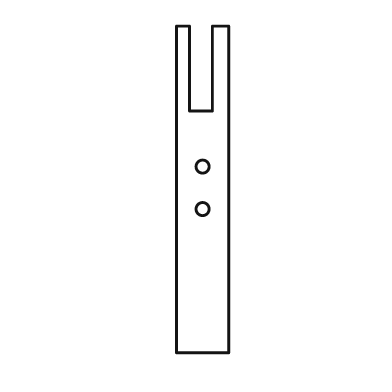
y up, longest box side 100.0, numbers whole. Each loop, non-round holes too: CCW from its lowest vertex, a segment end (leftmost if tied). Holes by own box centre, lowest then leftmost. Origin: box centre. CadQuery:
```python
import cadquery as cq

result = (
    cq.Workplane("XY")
    .moveTo(-8.0, -50.0)
    .lineTo(8.0, -50.0)
    .lineTo(8.0, 50.0)
    .lineTo(3.0, 50.0)
    .lineTo(3.0, 24.0)
    .lineTo(-4.0, 24.0)
    .lineTo(-4.0, 50.0)
    .lineTo(-8.0, 50.0)
    .close()
    .moveTo(0.0, -6.0)
    .circle(2.0)
    .moveTo(0.0, 7.0)
    .circle(2.0)
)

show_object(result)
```